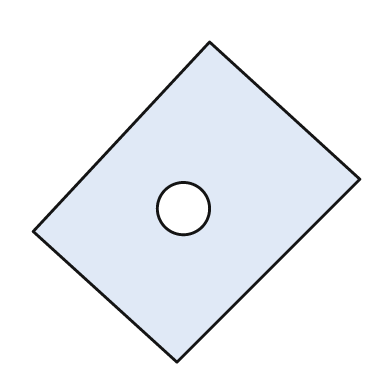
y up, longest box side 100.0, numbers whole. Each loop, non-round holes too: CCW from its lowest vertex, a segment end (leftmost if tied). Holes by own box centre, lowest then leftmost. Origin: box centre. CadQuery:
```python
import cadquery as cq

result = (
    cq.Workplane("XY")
    .moveTo(-6.0, -49.0)
    .lineTo(50.0, 7.0)
    .lineTo(4.0, 49.0)
    .lineTo(-50.0, -9.0)
    .close()
    .moveTo(-4.0, -2.0)
    .circle(8.0)
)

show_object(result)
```